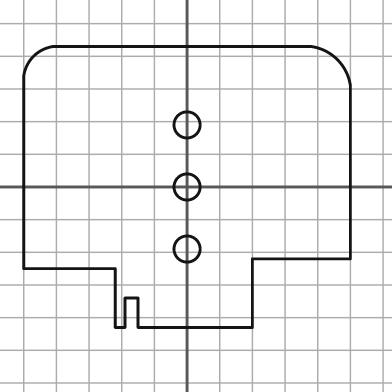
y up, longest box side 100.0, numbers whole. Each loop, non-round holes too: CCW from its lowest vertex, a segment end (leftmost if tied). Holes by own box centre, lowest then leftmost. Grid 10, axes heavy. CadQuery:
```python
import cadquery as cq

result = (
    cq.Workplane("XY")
    .moveTo(-22.0, -43.0)
    .lineTo(-19.0, -43.0)
    .lineTo(-19.0, -34.0)
    .lineTo(-15.0, -34.0)
    .lineTo(-15.0, -43.0)
    .lineTo(20.0, -43.0)
    .lineTo(20.0, -22.0)
    .lineTo(50.0, -22.0)
    .lineTo(50.0, 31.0)
    .threePointArc((46.0, 39.0), (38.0, 43.0))
    .lineTo(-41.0, 43.0)
    .threePointArc((-47.0, 40.0), (-50.0, 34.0))
    .lineTo(-50.0, -25.0)
    .lineTo(-22.0, -25.0)
    .close()
    .moveTo(0.0, -19.0)
    .circle(4.0)
    .moveTo(0.0, 0.0)
    .circle(4.0)
    .moveTo(0.0, 19.0)
    .circle(4.0)
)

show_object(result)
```